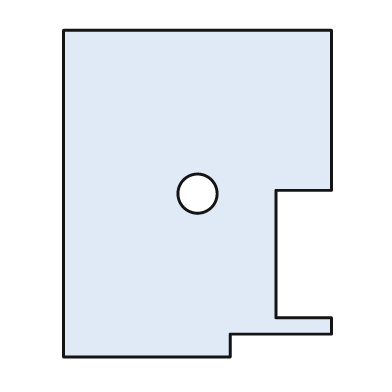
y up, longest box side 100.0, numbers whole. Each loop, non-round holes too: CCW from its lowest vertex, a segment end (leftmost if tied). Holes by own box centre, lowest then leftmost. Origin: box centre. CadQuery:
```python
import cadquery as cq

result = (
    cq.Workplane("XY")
    .moveTo(-41.0, -50.0)
    .lineTo(10.0, -50.0)
    .lineTo(10.0, -43.0)
    .lineTo(41.0, -43.0)
    .lineTo(41.0, -38.0)
    .lineTo(24.0, -38.0)
    .lineTo(24.0, 1.0)
    .lineTo(41.0, 1.0)
    .lineTo(41.0, 50.0)
    .lineTo(-41.0, 50.0)
    .close()
    .moveTo(0.0, 0.0)
    .circle(6.0)
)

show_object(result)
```